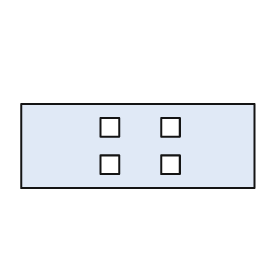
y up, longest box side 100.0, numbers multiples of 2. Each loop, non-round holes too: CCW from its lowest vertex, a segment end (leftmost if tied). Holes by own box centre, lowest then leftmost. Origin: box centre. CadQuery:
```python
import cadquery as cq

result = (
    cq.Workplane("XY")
    .moveTo(-50.0, -18.0)
    .lineTo(50.0, -18.0)
    .lineTo(50.0, 18.0)
    .lineTo(-50.0, 18.0)
    .close()
    .moveTo(-16.0, -12.0)
    .lineTo(-8.0, -12.0)
    .lineTo(-8.0, -4.0)
    .lineTo(-16.0, -4.0)
    .close()
    .moveTo(10.0, -12.0)
    .lineTo(18.0, -12.0)
    .lineTo(18.0, -4.0)
    .lineTo(10.0, -4.0)
    .close()
    .moveTo(-16.0, 4.0)
    .lineTo(-8.0, 4.0)
    .lineTo(-8.0, 12.0)
    .lineTo(-16.0, 12.0)
    .close()
    .moveTo(10.0, 4.0)
    .lineTo(18.0, 4.0)
    .lineTo(18.0, 12.0)
    .lineTo(10.0, 12.0)
    .close()
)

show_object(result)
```